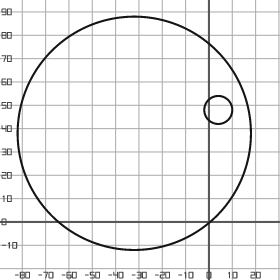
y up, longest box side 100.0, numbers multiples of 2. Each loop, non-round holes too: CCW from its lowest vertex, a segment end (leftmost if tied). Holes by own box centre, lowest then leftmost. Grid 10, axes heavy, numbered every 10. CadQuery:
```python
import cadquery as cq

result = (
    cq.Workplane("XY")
    .moveTo(-32.0, 38.0)
    .circle(50.0)
    .moveTo(4.0, 48.0)
    .circle(6.0)
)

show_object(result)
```